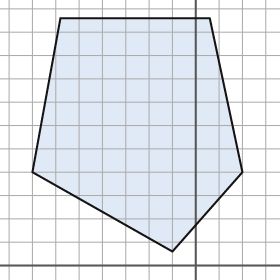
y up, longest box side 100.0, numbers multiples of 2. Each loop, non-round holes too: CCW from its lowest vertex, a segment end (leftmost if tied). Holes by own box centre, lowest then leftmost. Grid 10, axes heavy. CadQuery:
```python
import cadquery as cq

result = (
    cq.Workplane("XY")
    .moveTo(-10.0, 6.0)
    .lineTo(20.0, 40.0)
    .lineTo(6.0, 106.0)
    .lineTo(-58.0, 106.0)
    .lineTo(-70.0, 40.0)
    .close()
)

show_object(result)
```